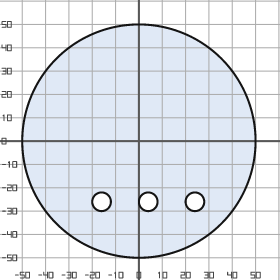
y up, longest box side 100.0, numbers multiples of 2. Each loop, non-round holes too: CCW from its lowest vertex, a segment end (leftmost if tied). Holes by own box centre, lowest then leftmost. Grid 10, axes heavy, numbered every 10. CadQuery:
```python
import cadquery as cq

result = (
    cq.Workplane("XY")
    .moveTo(0.0, 0.0)
    .circle(50.0)
    .moveTo(-16.0, -26.0)
    .circle(4.0)
    .moveTo(4.0, -26.0)
    .circle(4.0)
    .moveTo(24.0, -26.0)
    .circle(4.0)
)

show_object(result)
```